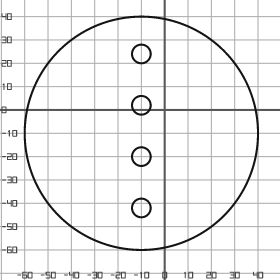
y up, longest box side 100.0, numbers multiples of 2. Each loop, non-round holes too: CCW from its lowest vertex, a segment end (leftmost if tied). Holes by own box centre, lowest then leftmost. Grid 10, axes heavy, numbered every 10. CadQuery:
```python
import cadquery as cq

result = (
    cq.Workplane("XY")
    .moveTo(-10.0, -10.0)
    .circle(50.0)
    .moveTo(-10.0, -42.0)
    .circle(4.0)
    .moveTo(-10.0, -20.0)
    .circle(4.0)
    .moveTo(-10.0, 2.0)
    .circle(4.0)
    .moveTo(-10.0, 24.0)
    .circle(4.0)
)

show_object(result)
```